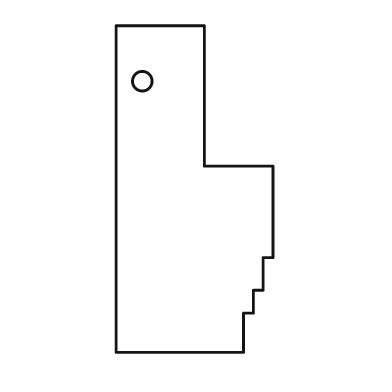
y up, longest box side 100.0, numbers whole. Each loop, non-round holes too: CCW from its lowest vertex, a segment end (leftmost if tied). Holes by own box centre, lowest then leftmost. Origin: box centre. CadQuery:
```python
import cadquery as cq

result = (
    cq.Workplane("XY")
    .moveTo(-24.0, -50.0)
    .lineTo(15.0, -50.0)
    .lineTo(15.0, -38.0)
    .lineTo(18.0, -38.0)
    .lineTo(18.0, -31.0)
    .lineTo(21.0, -31.0)
    .lineTo(21.0, -21.0)
    .lineTo(24.0, -21.0)
    .lineTo(24.0, 7.0)
    .lineTo(3.0, 7.0)
    .lineTo(3.0, 50.0)
    .lineTo(-24.0, 50.0)
    .close()
    .moveTo(-16.0, 33.0)
    .circle(3.0)
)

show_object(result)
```